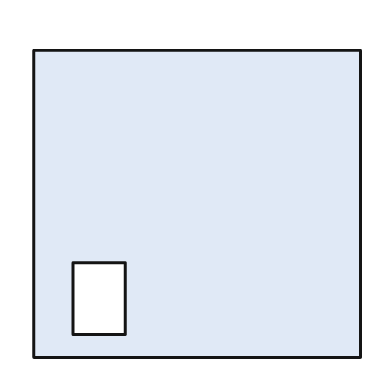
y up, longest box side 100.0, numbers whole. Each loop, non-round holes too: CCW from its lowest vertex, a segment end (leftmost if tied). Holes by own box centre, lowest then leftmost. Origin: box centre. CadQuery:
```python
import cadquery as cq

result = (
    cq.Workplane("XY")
    .moveTo(-50.0, -47.0)
    .lineTo(50.0, -47.0)
    .lineTo(50.0, 47.0)
    .lineTo(-50.0, 47.0)
    .close()
    .moveTo(-38.0, -40.0)
    .lineTo(-22.0, -40.0)
    .lineTo(-22.0, -18.0)
    .lineTo(-38.0, -18.0)
    .close()
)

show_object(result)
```